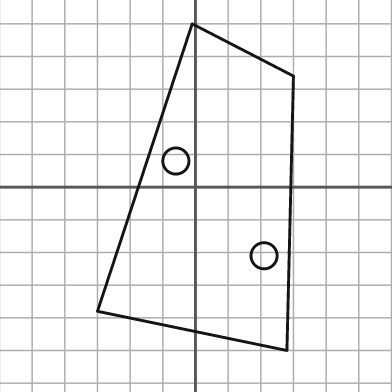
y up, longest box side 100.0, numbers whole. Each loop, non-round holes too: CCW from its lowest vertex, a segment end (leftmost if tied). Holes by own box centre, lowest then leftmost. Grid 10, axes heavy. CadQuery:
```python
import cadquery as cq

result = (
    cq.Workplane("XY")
    .moveTo(28.0, -50.0)
    .lineTo(30.0, 34.0)
    .lineTo(-1.0, 50.0)
    .lineTo(-30.0, -38.0)
    .close()
    .moveTo(21.0, -21.0)
    .circle(4.0)
    .moveTo(-6.0, 8.0)
    .circle(4.0)
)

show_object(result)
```